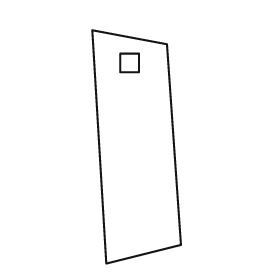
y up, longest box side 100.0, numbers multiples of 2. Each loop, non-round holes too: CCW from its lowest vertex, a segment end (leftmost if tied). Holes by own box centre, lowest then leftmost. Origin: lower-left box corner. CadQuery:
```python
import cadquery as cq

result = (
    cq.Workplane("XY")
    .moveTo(6.0, 0.0)
    .lineTo(38.0, 8.0)
    .lineTo(32.0, 94.0)
    .lineTo(0.0, 100.0)
    .close()
    .moveTo(12.0, 82.0)
    .lineTo(20.0, 82.0)
    .lineTo(20.0, 90.0)
    .lineTo(12.0, 90.0)
    .close()
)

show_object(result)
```